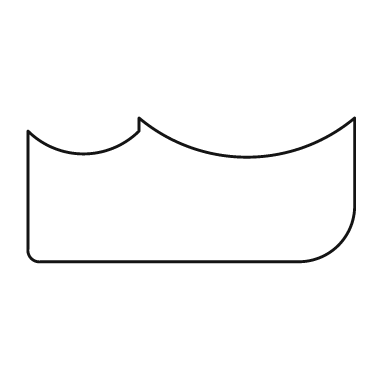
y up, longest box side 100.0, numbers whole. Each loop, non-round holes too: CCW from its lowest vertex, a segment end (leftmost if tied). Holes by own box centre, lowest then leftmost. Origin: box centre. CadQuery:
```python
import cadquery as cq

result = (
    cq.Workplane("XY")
    .moveTo(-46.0, -22.0)
    .lineTo(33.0, -22.0)
    .threePointArc((45.0, -17.0), (50.0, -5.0))
    .lineTo(50.0, 22.0)
    .threePointArc((17.0, 10.0), (-16.0, 22.0))
    .lineTo(-16.0, 18.0)
    .threePointArc((-33.0, 11.0), (-50.0, 18.0))
    .lineTo(-50.0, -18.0)
    .threePointArc((-49.0, -21.0), (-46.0, -22.0))
    .close()
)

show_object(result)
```